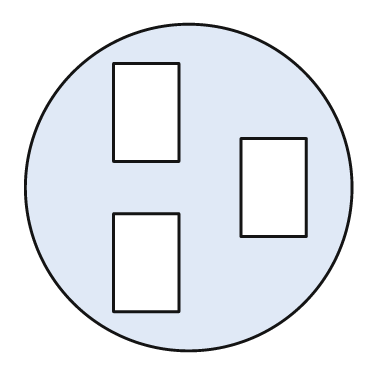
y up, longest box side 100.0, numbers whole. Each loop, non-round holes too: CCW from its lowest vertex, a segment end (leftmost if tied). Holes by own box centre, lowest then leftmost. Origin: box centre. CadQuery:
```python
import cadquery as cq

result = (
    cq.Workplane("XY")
    .moveTo(0.0, 0.0)
    .circle(50.0)
    .moveTo(-23.0, -38.0)
    .lineTo(-3.0, -38.0)
    .lineTo(-3.0, -8.0)
    .lineTo(-23.0, -8.0)
    .close()
    .moveTo(16.0, -15.0)
    .lineTo(36.0, -15.0)
    .lineTo(36.0, 15.0)
    .lineTo(16.0, 15.0)
    .close()
    .moveTo(-23.0, 8.0)
    .lineTo(-3.0, 8.0)
    .lineTo(-3.0, 38.0)
    .lineTo(-23.0, 38.0)
    .close()
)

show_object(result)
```